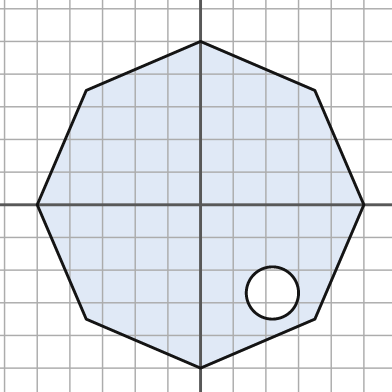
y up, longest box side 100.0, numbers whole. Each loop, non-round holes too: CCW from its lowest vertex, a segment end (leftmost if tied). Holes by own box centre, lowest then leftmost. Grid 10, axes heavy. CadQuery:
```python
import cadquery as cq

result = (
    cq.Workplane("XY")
    .moveTo(0.0, -50.0)
    .lineTo(35.0, -35.0)
    .lineTo(50.0, 0.0)
    .lineTo(35.0, 35.0)
    .lineTo(0.0, 50.0)
    .lineTo(-35.0, 35.0)
    .lineTo(-50.0, 0.0)
    .lineTo(-35.0, -35.0)
    .close()
    .moveTo(22.0, -27.0)
    .circle(8.0)
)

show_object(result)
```